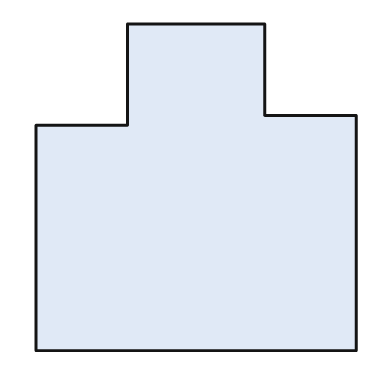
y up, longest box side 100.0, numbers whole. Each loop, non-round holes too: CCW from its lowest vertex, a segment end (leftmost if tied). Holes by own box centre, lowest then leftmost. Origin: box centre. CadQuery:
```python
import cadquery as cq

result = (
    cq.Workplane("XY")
    .moveTo(-49.0, -50.0)
    .lineTo(49.0, -50.0)
    .lineTo(49.0, 22.0)
    .lineTo(21.0, 22.0)
    .lineTo(21.0, 50.0)
    .lineTo(-21.0, 50.0)
    .lineTo(-21.0, 19.0)
    .lineTo(-49.0, 19.0)
    .close()
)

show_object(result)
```